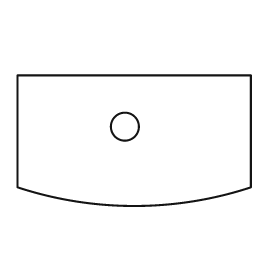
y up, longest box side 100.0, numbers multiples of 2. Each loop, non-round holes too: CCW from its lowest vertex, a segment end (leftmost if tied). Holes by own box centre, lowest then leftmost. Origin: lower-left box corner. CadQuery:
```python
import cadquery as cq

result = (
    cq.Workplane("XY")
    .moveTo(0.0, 8.0)
    .threePointArc((50.0, 0.0), (100.0, 8.0))
    .lineTo(100.0, 56.0)
    .lineTo(0.0, 56.0)
    .close()
    .moveTo(46.0, 34.0)
    .circle(6.0)
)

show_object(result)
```